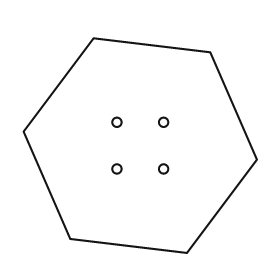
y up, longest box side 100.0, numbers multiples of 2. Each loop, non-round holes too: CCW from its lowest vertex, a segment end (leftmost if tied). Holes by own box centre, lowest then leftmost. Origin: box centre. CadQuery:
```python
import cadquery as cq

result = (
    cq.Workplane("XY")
    .moveTo(20.0, -46.0)
    .lineTo(50.0, -6.0)
    .lineTo(30.0, 40.0)
    .lineTo(-20.0, 46.0)
    .lineTo(-50.0, 6.0)
    .lineTo(-30.0, -40.0)
    .close()
    .moveTo(-10.0, -10.0)
    .circle(2.0)
    .moveTo(10.0, -10.0)
    .circle(2.0)
    .moveTo(-10.0, 10.0)
    .circle(2.0)
    .moveTo(10.0, 10.0)
    .circle(2.0)
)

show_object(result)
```